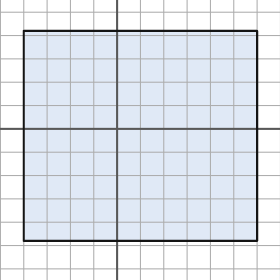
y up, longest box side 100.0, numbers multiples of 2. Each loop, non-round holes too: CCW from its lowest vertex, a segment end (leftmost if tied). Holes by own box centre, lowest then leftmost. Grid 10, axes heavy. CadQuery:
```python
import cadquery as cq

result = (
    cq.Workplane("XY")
    .moveTo(-40.0, -48.0)
    .lineTo(60.0, -48.0)
    .lineTo(60.0, 42.0)
    .lineTo(-40.0, 42.0)
    .close()
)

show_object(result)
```